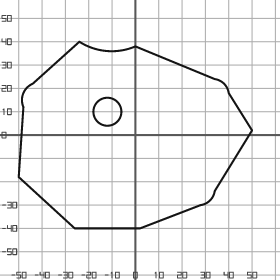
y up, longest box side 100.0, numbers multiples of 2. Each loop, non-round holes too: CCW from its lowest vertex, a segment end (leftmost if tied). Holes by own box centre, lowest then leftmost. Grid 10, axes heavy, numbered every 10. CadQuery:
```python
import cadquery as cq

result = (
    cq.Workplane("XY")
    .moveTo(-26.0, -40.0)
    .lineTo(2.0, -40.0)
    .lineTo(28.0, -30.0)
    .threePointArc((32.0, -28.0), (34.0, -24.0))
    .lineTo(50.0, 2.0)
    .lineTo(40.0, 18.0)
    .threePointArc((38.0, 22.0), (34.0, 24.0))
    .lineTo(0.0, 38.0)
    .threePointArc((-12.0, 36.0), (-24.0, 40.0))
    .lineTo(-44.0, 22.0)
    .threePointArc((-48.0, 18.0), (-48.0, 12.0))
    .lineTo(-50.0, -18.0)
    .close()
    .moveTo(-12.0, 10.0)
    .circle(6.0)
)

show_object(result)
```